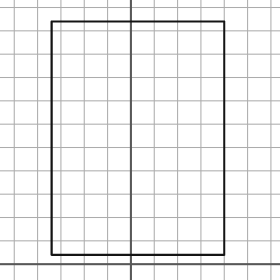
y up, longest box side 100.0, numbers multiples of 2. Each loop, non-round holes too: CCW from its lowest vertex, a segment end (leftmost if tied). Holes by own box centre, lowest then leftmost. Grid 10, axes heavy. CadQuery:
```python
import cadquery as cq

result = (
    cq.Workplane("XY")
    .moveTo(-34.0, 4.0)
    .lineTo(40.0, 4.0)
    .lineTo(40.0, 104.0)
    .lineTo(-34.0, 104.0)
    .close()
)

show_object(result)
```